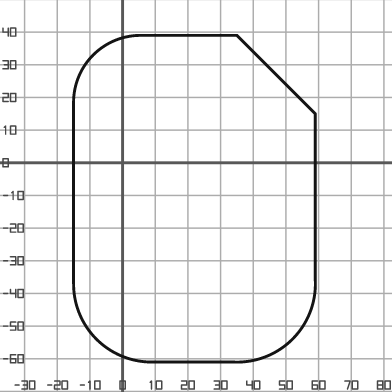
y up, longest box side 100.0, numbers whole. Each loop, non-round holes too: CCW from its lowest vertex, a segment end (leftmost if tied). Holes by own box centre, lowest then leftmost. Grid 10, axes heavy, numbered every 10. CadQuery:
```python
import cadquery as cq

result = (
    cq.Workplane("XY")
    .moveTo(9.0, -61.0)
    .lineTo(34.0, -61.0)
    .threePointArc((52.0, -54.0), (59.0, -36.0))
    .lineTo(59.0, 15.0)
    .lineTo(35.0, 39.0)
    .lineTo(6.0, 39.0)
    .threePointArc((-9.0, 33.0), (-15.0, 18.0))
    .lineTo(-15.0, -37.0)
    .threePointArc((-8.0, -54.0), (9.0, -61.0))
    .close()
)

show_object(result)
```